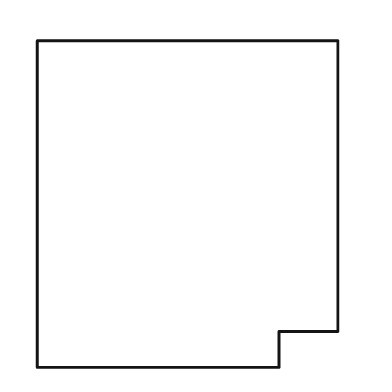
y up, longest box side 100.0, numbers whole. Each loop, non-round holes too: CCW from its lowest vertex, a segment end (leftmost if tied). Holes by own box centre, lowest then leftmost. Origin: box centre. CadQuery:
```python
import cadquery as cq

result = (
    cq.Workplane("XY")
    .moveTo(-46.0, -50.0)
    .lineTo(28.0, -50.0)
    .lineTo(28.0, -39.0)
    .lineTo(46.0, -39.0)
    .lineTo(46.0, 50.0)
    .lineTo(-46.0, 50.0)
    .close()
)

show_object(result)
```